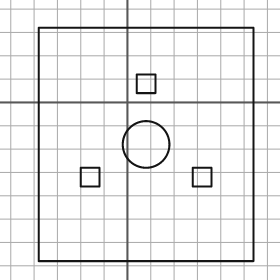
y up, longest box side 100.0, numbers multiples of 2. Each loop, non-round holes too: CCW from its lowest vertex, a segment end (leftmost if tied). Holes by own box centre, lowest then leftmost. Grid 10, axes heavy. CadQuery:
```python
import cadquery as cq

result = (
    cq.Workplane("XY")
    .moveTo(-38.0, -68.0)
    .lineTo(54.0, -68.0)
    .lineTo(54.0, 32.0)
    .lineTo(-38.0, 32.0)
    .close()
    .moveTo(-20.0, -36.0)
    .lineTo(-12.0, -36.0)
    .lineTo(-12.0, -28.0)
    .lineTo(-20.0, -28.0)
    .close()
    .moveTo(28.0, -36.0)
    .lineTo(36.0, -36.0)
    .lineTo(36.0, -28.0)
    .lineTo(28.0, -28.0)
    .close()
    .moveTo(8.0, -18.0)
    .circle(10.0)
    .moveTo(4.0, 4.0)
    .lineTo(12.0, 4.0)
    .lineTo(12.0, 12.0)
    .lineTo(4.0, 12.0)
    .close()
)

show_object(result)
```